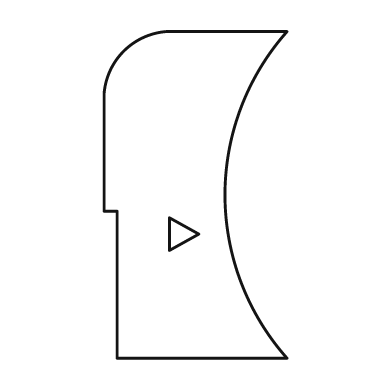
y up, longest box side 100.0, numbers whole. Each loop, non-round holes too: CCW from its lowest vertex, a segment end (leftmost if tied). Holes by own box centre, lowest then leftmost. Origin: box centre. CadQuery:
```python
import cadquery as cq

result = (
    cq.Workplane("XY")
    .moveTo(-24.0, -50.0)
    .lineTo(28.0, -50.0)
    .threePointArc((9.0, 0.0), (28.0, 50.0))
    .lineTo(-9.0, 50.0)
    .threePointArc((-22.0, 44.0), (-28.0, 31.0))
    .lineTo(-28.0, -5.0)
    .lineTo(-24.0, -5.0)
    .close()
    .moveTo(-8.0, -17.0)
    .lineTo(1.0, -12.0)
    .lineTo(-8.0, -7.0)
    .close()
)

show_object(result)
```